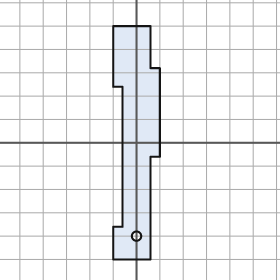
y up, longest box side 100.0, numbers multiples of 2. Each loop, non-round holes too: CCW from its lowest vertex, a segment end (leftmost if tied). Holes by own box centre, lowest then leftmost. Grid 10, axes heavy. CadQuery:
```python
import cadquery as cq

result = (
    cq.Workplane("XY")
    .moveTo(-10.0, -50.0)
    .lineTo(6.0, -50.0)
    .lineTo(6.0, -6.0)
    .lineTo(10.0, -6.0)
    .lineTo(10.0, 32.0)
    .lineTo(6.0, 32.0)
    .lineTo(6.0, 50.0)
    .lineTo(-10.0, 50.0)
    .lineTo(-10.0, 24.0)
    .lineTo(-6.0, 24.0)
    .lineTo(-6.0, -36.0)
    .lineTo(-10.0, -36.0)
    .close()
    .moveTo(0.0, -40.0)
    .circle(2.0)
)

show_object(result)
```